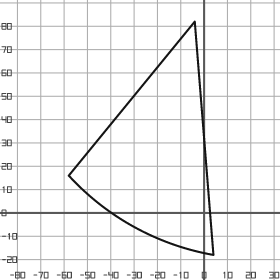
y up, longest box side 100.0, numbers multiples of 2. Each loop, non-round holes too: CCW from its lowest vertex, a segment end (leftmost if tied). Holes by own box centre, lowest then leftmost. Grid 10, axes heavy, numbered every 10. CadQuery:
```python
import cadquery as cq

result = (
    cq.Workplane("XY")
    .moveTo(4.0, -18.0)
    .lineTo(-4.0, 82.0)
    .lineTo(-58.0, 16.0)
    .threePointArc((-30.0, -6.0), (4.0, -18.0))
    .close()
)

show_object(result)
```